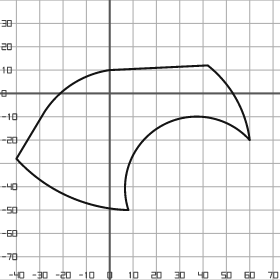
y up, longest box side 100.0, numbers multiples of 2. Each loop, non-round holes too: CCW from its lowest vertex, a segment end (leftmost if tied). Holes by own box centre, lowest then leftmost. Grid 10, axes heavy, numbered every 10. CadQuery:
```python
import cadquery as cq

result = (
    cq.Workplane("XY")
    .moveTo(8.0, -50.0)
    .threePointArc((22.0, -14.0), (60.0, -20.0))
    .threePointArc((54.0, -2.0), (42.0, 12.0))
    .lineTo(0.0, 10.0)
    .threePointArc((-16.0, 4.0), (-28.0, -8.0))
    .lineTo(-40.0, -28.0)
    .threePointArc((-18.0, -44.0), (8.0, -50.0))
    .close()
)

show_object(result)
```